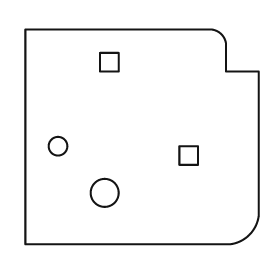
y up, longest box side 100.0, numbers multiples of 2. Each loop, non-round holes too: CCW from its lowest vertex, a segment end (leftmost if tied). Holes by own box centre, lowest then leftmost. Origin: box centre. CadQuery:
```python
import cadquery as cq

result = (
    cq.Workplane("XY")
    .moveTo(-50.0, -46.0)
    .lineTo(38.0, -46.0)
    .threePointArc((46.0, -42.0), (50.0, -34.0))
    .lineTo(50.0, 28.0)
    .lineTo(36.0, 28.0)
    .lineTo(36.0, 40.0)
    .threePointArc((34.0, 44.0), (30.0, 46.0))
    .lineTo(-50.0, 46.0)
    .close()
    .moveTo(-16.0, -24.0)
    .circle(6.0)
    .moveTo(16.0, -12.0)
    .lineTo(24.0, -12.0)
    .lineTo(24.0, -4.0)
    .lineTo(16.0, -4.0)
    .close()
    .moveTo(-36.0, -4.0)
    .circle(4.0)
    .moveTo(-18.0, 28.0)
    .lineTo(-10.0, 28.0)
    .lineTo(-10.0, 36.0)
    .lineTo(-18.0, 36.0)
    .close()
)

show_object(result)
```